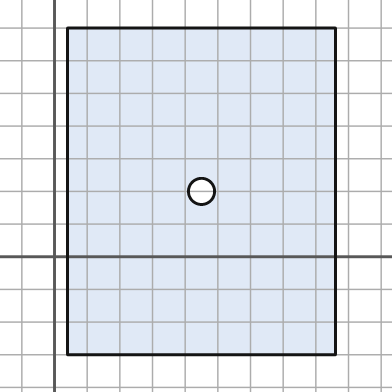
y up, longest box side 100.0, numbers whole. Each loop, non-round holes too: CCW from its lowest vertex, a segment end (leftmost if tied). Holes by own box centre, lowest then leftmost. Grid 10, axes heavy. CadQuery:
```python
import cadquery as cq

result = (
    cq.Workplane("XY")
    .moveTo(4.0, -30.0)
    .lineTo(86.0, -30.0)
    .lineTo(86.0, 70.0)
    .lineTo(4.0, 70.0)
    .close()
    .moveTo(45.0, 20.0)
    .circle(4.0)
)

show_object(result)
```